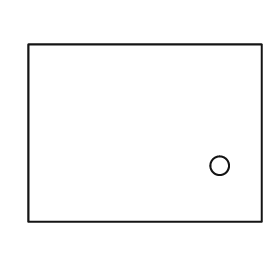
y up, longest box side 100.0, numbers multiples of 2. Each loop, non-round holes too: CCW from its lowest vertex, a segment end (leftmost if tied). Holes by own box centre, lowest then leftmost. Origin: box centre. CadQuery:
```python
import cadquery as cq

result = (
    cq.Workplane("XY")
    .moveTo(-50.0, -38.0)
    .lineTo(50.0, -38.0)
    .lineTo(50.0, 38.0)
    .lineTo(-50.0, 38.0)
    .close()
    .moveTo(32.0, -14.0)
    .circle(4.0)
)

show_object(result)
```